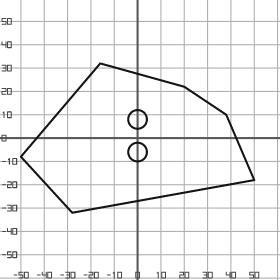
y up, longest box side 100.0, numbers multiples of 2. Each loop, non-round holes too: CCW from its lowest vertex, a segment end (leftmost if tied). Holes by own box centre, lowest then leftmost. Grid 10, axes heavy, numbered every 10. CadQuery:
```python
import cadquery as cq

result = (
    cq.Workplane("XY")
    .moveTo(-28.0, -32.0)
    .lineTo(50.0, -18.0)
    .lineTo(38.0, 10.0)
    .lineTo(20.0, 22.0)
    .lineTo(-16.0, 32.0)
    .lineTo(-50.0, -8.0)
    .close()
    .moveTo(0.0, -6.0)
    .circle(4.0)
    .moveTo(0.0, 8.0)
    .circle(4.0)
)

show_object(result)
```